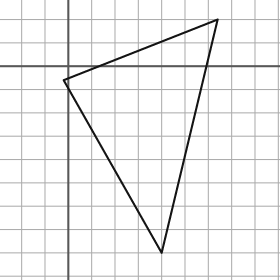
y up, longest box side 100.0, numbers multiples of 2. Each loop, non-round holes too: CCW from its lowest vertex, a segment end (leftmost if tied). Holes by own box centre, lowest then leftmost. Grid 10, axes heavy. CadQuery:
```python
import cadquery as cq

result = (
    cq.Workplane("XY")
    .moveTo(40.0, -80.0)
    .lineTo(64.0, 20.0)
    .lineTo(-2.0, -6.0)
    .close()
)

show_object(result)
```